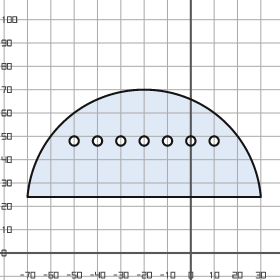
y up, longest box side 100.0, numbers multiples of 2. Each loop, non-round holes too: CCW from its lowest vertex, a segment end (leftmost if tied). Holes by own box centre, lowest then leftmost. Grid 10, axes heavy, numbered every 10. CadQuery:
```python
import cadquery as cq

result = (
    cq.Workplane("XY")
    .moveTo(-70.0, 24.0)
    .lineTo(30.0, 24.0)
    .threePointArc((-20.0, 70.0), (-70.0, 24.0))
    .close()
    .moveTo(-50.0, 48.0)
    .circle(2.0)
    .moveTo(-40.0, 48.0)
    .circle(2.0)
    .moveTo(-30.0, 48.0)
    .circle(2.0)
    .moveTo(-20.0, 48.0)
    .circle(2.0)
    .moveTo(-10.0, 48.0)
    .circle(2.0)
    .moveTo(0.0, 48.0)
    .circle(2.0)
    .moveTo(10.0, 48.0)
    .circle(2.0)
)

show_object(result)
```